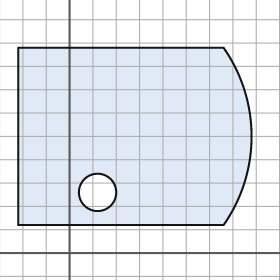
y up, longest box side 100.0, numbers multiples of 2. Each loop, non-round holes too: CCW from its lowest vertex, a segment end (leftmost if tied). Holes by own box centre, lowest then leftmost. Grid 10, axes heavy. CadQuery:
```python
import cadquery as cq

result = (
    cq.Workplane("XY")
    .moveTo(-22.0, 12.0)
    .lineTo(66.0, 12.0)
    .threePointArc((78.0, 50.0), (66.0, 88.0))
    .lineTo(-22.0, 88.0)
    .close()
    .moveTo(12.0, 26.0)
    .circle(8.0)
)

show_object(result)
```